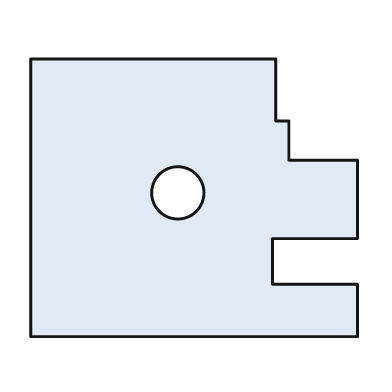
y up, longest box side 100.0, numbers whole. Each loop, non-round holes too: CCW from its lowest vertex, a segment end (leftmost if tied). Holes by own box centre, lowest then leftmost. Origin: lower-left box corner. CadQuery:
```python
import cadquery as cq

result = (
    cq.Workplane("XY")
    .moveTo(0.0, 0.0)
    .lineTo(100.0, 0.0)
    .lineTo(100.0, 16.0)
    .lineTo(74.0, 16.0)
    .lineTo(74.0, 30.0)
    .lineTo(100.0, 30.0)
    .lineTo(100.0, 54.0)
    .lineTo(79.0, 54.0)
    .lineTo(79.0, 66.0)
    .lineTo(75.0, 66.0)
    .lineTo(75.0, 85.0)
    .lineTo(0.0, 85.0)
    .close()
    .moveTo(45.0, 44.0)
    .circle(8.0)
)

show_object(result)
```